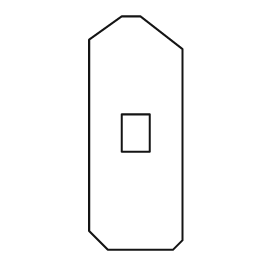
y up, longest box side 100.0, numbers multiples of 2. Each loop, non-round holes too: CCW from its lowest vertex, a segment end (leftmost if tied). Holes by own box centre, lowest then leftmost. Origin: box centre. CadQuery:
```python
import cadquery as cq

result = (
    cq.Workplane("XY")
    .moveTo(-12.0, -50.0)
    .lineTo(16.0, -50.0)
    .lineTo(20.0, -46.0)
    .lineTo(20.0, 36.0)
    .lineTo(2.0, 50.0)
    .lineTo(-6.0, 50.0)
    .lineTo(-20.0, 40.0)
    .lineTo(-20.0, -42.0)
    .close()
    .moveTo(-6.0, -8.0)
    .lineTo(6.0, -8.0)
    .lineTo(6.0, 8.0)
    .lineTo(-6.0, 8.0)
    .close()
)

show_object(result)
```